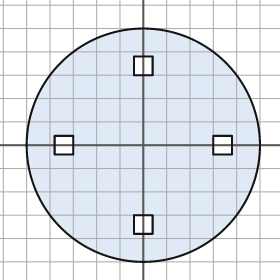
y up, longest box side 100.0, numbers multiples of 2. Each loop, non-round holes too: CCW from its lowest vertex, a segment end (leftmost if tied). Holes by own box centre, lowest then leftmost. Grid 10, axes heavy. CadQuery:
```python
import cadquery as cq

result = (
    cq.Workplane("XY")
    .moveTo(0.0, 0.0)
    .circle(50.0)
    .moveTo(-4.0, -38.0)
    .lineTo(4.0, -38.0)
    .lineTo(4.0, -30.0)
    .lineTo(-4.0, -30.0)
    .close()
    .moveTo(-38.0, -4.0)
    .lineTo(-30.0, -4.0)
    .lineTo(-30.0, 4.0)
    .lineTo(-38.0, 4.0)
    .close()
    .moveTo(30.0, -4.0)
    .lineTo(38.0, -4.0)
    .lineTo(38.0, 4.0)
    .lineTo(30.0, 4.0)
    .close()
    .moveTo(-4.0, 30.0)
    .lineTo(4.0, 30.0)
    .lineTo(4.0, 38.0)
    .lineTo(-4.0, 38.0)
    .close()
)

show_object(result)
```